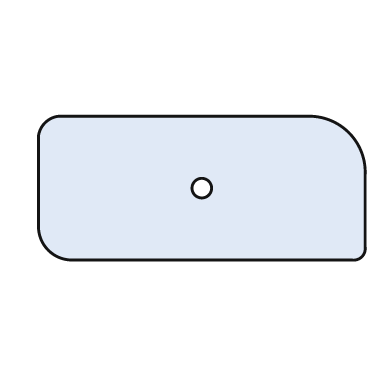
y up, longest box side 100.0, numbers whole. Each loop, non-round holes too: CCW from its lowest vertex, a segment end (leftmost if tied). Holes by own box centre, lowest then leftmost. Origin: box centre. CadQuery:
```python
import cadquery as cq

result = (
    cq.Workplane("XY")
    .moveTo(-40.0, -22.0)
    .lineTo(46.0, -22.0)
    .threePointArc((49.0, -21.0), (50.0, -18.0))
    .lineTo(50.0, 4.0)
    .threePointArc((45.0, 17.0), (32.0, 22.0))
    .lineTo(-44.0, 22.0)
    .threePointArc((-48.0, 20.0), (-50.0, 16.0))
    .lineTo(-50.0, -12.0)
    .threePointArc((-47.0, -19.0), (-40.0, -22.0))
    .close()
    .moveTo(0.0, 0.0)
    .circle(3.0)
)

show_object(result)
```